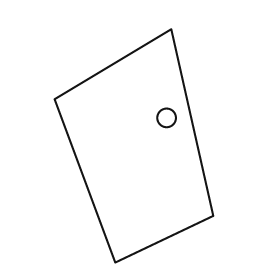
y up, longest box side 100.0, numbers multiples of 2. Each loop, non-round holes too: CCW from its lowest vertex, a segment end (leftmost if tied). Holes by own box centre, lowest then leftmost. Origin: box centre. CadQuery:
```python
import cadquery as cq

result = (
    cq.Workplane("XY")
    .moveTo(-8.0, -50.0)
    .lineTo(34.0, -30.0)
    .lineTo(16.0, 50.0)
    .lineTo(-34.0, 20.0)
    .close()
    .moveTo(14.0, 12.0)
    .circle(4.0)
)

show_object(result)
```